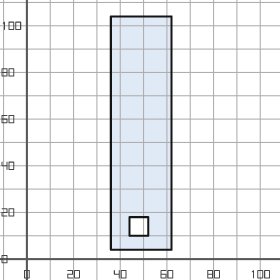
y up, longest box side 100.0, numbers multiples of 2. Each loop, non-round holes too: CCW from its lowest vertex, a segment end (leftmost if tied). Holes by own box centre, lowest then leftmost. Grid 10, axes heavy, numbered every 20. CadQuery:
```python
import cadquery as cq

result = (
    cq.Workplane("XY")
    .moveTo(36.0, 4.0)
    .lineTo(62.0, 4.0)
    .lineTo(62.0, 104.0)
    .lineTo(36.0, 104.0)
    .close()
    .moveTo(44.0, 10.0)
    .lineTo(52.0, 10.0)
    .lineTo(52.0, 18.0)
    .lineTo(44.0, 18.0)
    .close()
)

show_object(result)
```